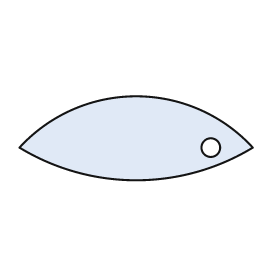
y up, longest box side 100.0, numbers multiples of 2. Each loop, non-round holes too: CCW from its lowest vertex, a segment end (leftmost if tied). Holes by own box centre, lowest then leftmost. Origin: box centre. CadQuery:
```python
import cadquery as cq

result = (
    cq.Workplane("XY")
    .moveTo(-50.0, -4.0)
    .threePointArc((0.0, -18.0), (50.0, -4.0))
    .threePointArc((0.0, 18.0), (-50.0, -4.0))
    .close()
    .moveTo(32.0, -4.0)
    .circle(4.0)
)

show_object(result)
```